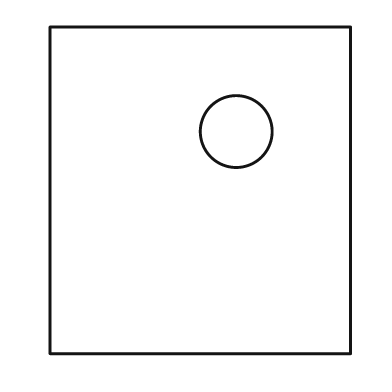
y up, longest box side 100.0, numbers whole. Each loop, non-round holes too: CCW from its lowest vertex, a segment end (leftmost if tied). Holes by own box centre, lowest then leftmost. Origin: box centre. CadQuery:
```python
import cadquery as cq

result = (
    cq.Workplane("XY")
    .moveTo(-46.0, -50.0)
    .lineTo(46.0, -50.0)
    .lineTo(46.0, 50.0)
    .lineTo(-46.0, 50.0)
    .close()
    .moveTo(11.0, 18.0)
    .circle(11.0)
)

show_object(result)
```